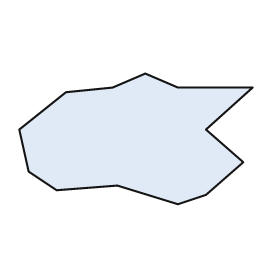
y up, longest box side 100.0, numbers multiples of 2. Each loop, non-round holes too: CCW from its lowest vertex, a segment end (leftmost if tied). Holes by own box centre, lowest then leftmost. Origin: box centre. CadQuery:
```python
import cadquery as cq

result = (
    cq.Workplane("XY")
    .moveTo(18.0, -28.0)
    .lineTo(30.0, -24.0)
    .lineTo(46.0, -10.0)
    .lineTo(30.0, 4.0)
    .lineTo(50.0, 22.0)
    .lineTo(18.0, 22.0)
    .lineTo(4.0, 28.0)
    .lineTo(-10.0, 22.0)
    .lineTo(-30.0, 20.0)
    .lineTo(-50.0, 4.0)
    .lineTo(-46.0, -14.0)
    .lineTo(-34.0, -22.0)
    .lineTo(-8.0, -20.0)
    .close()
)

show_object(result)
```